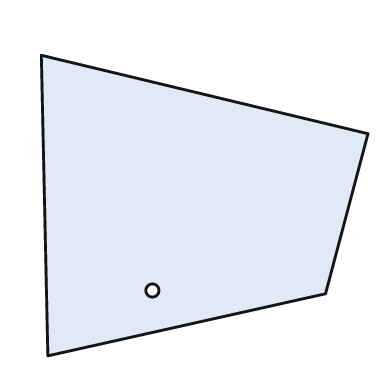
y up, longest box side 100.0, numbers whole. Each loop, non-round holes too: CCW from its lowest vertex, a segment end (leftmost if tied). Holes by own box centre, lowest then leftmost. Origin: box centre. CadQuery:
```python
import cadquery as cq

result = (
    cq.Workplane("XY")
    .moveTo(-48.0, -46.0)
    .lineTo(37.0, -27.0)
    .lineTo(50.0, 22.0)
    .lineTo(-50.0, 46.0)
    .close()
    .moveTo(-16.0, -26.0)
    .circle(2.0)
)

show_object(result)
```